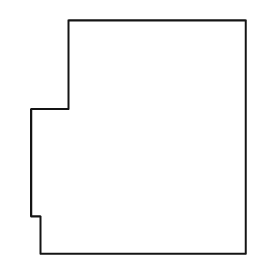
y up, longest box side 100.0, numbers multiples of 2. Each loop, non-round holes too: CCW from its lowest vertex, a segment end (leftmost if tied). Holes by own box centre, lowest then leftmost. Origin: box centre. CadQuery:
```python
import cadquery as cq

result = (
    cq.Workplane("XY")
    .moveTo(-42.0, -50.0)
    .lineTo(46.0, -50.0)
    .lineTo(46.0, 50.0)
    .lineTo(-30.0, 50.0)
    .lineTo(-30.0, 12.0)
    .lineTo(-46.0, 12.0)
    .lineTo(-46.0, -34.0)
    .lineTo(-42.0, -34.0)
    .close()
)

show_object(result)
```